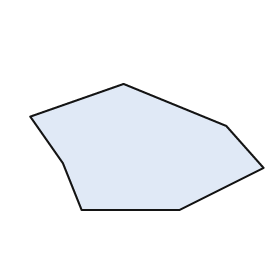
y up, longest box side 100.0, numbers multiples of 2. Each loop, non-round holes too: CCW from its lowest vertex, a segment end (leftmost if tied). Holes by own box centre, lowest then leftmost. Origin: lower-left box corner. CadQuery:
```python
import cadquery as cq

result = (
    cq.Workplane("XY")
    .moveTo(22.0, 0.0)
    .lineTo(64.0, 0.0)
    .lineTo(100.0, 18.0)
    .lineTo(84.0, 36.0)
    .lineTo(40.0, 54.0)
    .lineTo(0.0, 40.0)
    .lineTo(14.0, 20.0)
    .close()
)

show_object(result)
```